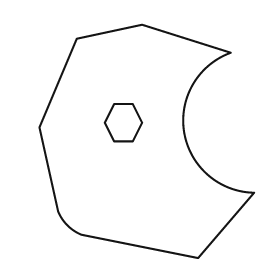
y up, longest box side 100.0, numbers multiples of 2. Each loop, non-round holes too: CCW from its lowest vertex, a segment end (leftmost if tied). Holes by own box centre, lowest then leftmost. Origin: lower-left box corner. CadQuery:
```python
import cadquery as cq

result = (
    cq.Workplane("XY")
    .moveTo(68.0, 0.0)
    .lineTo(92.0, 28.0)
    .threePointArc((62.0, 54.0), (82.0, 88.0))
    .lineTo(44.0, 100.0)
    .lineTo(16.0, 94.0)
    .lineTo(0.0, 56.0)
    .lineTo(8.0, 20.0)
    .threePointArc((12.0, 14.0), (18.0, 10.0))
    .close()
    .moveTo(32.0, 50.0)
    .lineTo(40.0, 50.0)
    .lineTo(44.0, 58.0)
    .lineTo(40.0, 66.0)
    .lineTo(32.0, 66.0)
    .lineTo(28.0, 58.0)
    .close()
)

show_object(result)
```